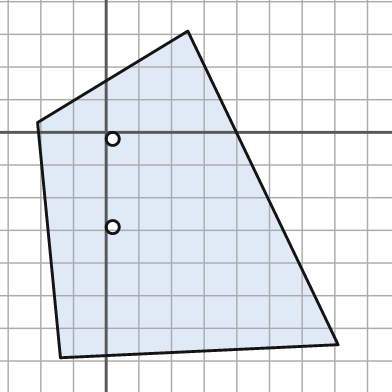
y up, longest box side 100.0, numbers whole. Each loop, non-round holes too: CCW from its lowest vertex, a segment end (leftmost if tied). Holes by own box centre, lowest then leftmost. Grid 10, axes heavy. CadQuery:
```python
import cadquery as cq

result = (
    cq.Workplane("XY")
    .moveTo(-14.0, -69.0)
    .lineTo(71.0, -65.0)
    .lineTo(25.0, 31.0)
    .lineTo(-21.0, 3.0)
    .close()
    .moveTo(2.0, -29.0)
    .circle(2.0)
    .moveTo(2.0, -2.0)
    .circle(2.0)
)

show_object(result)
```